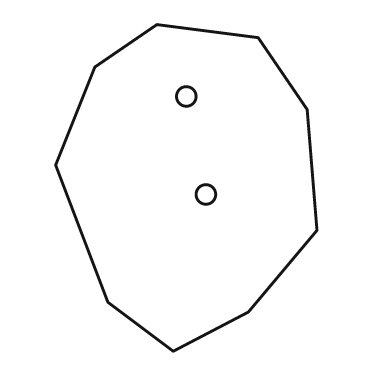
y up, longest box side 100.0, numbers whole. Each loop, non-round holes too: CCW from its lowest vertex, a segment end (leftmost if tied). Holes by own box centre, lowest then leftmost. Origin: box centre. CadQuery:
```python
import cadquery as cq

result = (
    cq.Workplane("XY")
    .moveTo(-4.0, -50.0)
    .lineTo(19.0, -38.0)
    .lineTo(40.0, -13.0)
    .lineTo(37.0, 24.0)
    .lineTo(22.0, 46.0)
    .lineTo(-9.0, 50.0)
    .lineTo(-28.0, 37.0)
    .lineTo(-40.0, 7.0)
    .lineTo(-24.0, -35.0)
    .close()
    .moveTo(6.0, -2.0)
    .circle(3.0)
    .moveTo(0.0, 28.0)
    .circle(3.0)
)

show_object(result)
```